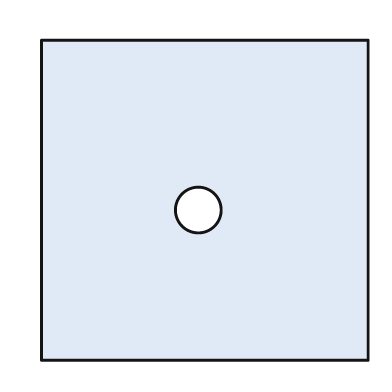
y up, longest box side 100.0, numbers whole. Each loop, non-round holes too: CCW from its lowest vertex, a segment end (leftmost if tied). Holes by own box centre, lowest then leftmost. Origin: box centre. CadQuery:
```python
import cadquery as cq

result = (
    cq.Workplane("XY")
    .moveTo(-50.0, -49.0)
    .lineTo(50.0, -49.0)
    .lineTo(50.0, 49.0)
    .lineTo(-50.0, 49.0)
    .close()
    .moveTo(-2.0, -3.0)
    .circle(7.0)
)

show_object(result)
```